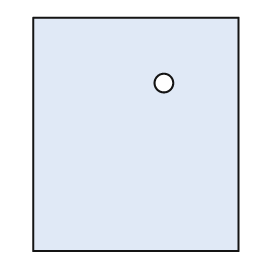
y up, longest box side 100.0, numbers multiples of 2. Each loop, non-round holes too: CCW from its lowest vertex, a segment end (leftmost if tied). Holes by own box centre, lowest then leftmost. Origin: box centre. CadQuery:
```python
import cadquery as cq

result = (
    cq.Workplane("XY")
    .moveTo(-44.0, -50.0)
    .lineTo(44.0, -50.0)
    .lineTo(44.0, 50.0)
    .lineTo(-44.0, 50.0)
    .close()
    .moveTo(12.0, 22.0)
    .circle(4.0)
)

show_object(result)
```